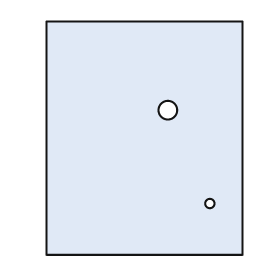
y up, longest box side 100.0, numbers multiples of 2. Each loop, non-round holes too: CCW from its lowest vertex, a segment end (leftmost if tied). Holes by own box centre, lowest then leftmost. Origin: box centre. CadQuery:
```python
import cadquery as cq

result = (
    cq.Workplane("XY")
    .moveTo(-42.0, -50.0)
    .lineTo(42.0, -50.0)
    .lineTo(42.0, 50.0)
    .lineTo(-42.0, 50.0)
    .close()
    .moveTo(28.0, -28.0)
    .circle(2.0)
    .moveTo(10.0, 12.0)
    .circle(4.0)
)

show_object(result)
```